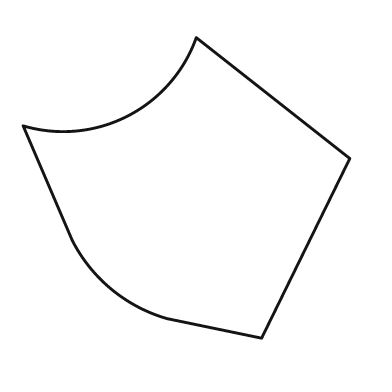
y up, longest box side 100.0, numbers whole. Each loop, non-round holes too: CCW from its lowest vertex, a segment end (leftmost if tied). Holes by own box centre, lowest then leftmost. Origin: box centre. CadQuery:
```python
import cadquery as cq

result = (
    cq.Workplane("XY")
    .moveTo(23.0, -46.0)
    .lineTo(50.0, 9.0)
    .lineTo(3.0, 46.0)
    .threePointArc((-18.0, 22.0), (-50.0, 19.0))
    .lineTo(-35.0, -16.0)
    .threePointArc((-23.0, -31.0), (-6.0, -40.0))
    .close()
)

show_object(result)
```